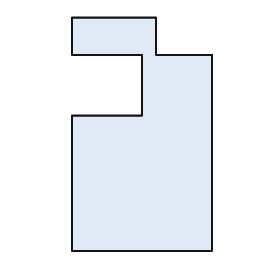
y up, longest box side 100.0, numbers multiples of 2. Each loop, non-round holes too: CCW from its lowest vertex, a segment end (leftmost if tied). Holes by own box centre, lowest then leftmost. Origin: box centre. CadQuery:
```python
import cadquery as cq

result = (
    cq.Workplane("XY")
    .moveTo(-30.0, -50.0)
    .lineTo(30.0, -50.0)
    .lineTo(30.0, 34.0)
    .lineTo(6.0, 34.0)
    .lineTo(6.0, 50.0)
    .lineTo(-30.0, 50.0)
    .lineTo(-30.0, 34.0)
    .lineTo(0.0, 34.0)
    .lineTo(0.0, 8.0)
    .lineTo(-30.0, 8.0)
    .close()
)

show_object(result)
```